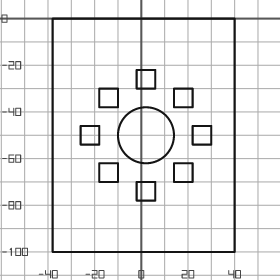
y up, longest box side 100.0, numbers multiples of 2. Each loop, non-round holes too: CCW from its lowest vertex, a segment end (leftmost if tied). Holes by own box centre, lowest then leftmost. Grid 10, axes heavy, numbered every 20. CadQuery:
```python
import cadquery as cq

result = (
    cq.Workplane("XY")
    .moveTo(-38.0, -100.0)
    .lineTo(40.0, -100.0)
    .lineTo(40.0, 0.0)
    .lineTo(-38.0, 0.0)
    .close()
    .moveTo(-2.0, -78.0)
    .lineTo(6.0, -78.0)
    .lineTo(6.0, -70.0)
    .lineTo(-2.0, -70.0)
    .close()
    .moveTo(-18.0, -70.0)
    .lineTo(-10.0, -70.0)
    .lineTo(-10.0, -62.0)
    .lineTo(-18.0, -62.0)
    .close()
    .moveTo(14.0, -70.0)
    .lineTo(22.0, -70.0)
    .lineTo(22.0, -62.0)
    .lineTo(14.0, -62.0)
    .close()
    .moveTo(-26.0, -54.0)
    .lineTo(-18.0, -54.0)
    .lineTo(-18.0, -46.0)
    .lineTo(-26.0, -46.0)
    .close()
    .moveTo(2.0, -50.0)
    .circle(12.0)
    .moveTo(22.0, -54.0)
    .lineTo(30.0, -54.0)
    .lineTo(30.0, -46.0)
    .lineTo(22.0, -46.0)
    .close()
    .moveTo(-18.0, -38.0)
    .lineTo(-10.0, -38.0)
    .lineTo(-10.0, -30.0)
    .lineTo(-18.0, -30.0)
    .close()
    .moveTo(14.0, -38.0)
    .lineTo(22.0, -38.0)
    .lineTo(22.0, -30.0)
    .lineTo(14.0, -30.0)
    .close()
    .moveTo(-2.0, -30.0)
    .lineTo(6.0, -30.0)
    .lineTo(6.0, -22.0)
    .lineTo(-2.0, -22.0)
    .close()
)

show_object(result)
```